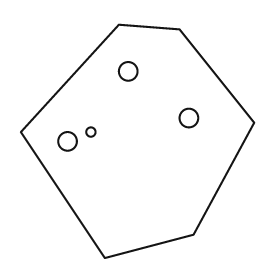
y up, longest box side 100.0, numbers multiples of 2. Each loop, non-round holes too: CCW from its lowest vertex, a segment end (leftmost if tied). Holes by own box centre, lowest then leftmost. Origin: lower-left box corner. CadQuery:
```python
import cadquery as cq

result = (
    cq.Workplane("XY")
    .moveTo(36.0, 0.0)
    .lineTo(74.0, 10.0)
    .lineTo(100.0, 58.0)
    .lineTo(68.0, 98.0)
    .lineTo(42.0, 100.0)
    .lineTo(0.0, 54.0)
    .close()
    .moveTo(20.0, 50.0)
    .circle(4.0)
    .moveTo(30.0, 54.0)
    .circle(2.0)
    .moveTo(72.0, 60.0)
    .circle(4.0)
    .moveTo(46.0, 80.0)
    .circle(4.0)
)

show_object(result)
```